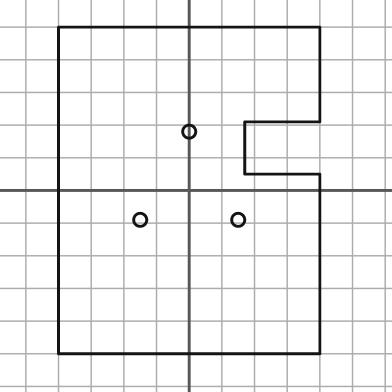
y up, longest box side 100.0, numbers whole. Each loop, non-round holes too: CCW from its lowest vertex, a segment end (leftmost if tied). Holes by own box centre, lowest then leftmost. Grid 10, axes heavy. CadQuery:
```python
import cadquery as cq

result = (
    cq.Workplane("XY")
    .moveTo(-40.0, -50.0)
    .lineTo(40.0, -50.0)
    .lineTo(40.0, 5.0)
    .lineTo(17.0, 5.0)
    .lineTo(17.0, 21.0)
    .lineTo(40.0, 21.0)
    .lineTo(40.0, 50.0)
    .lineTo(-40.0, 50.0)
    .close()
    .moveTo(-15.0, -9.0)
    .circle(2.0)
    .moveTo(15.0, -9.0)
    .circle(2.0)
    .moveTo(0.0, 18.0)
    .circle(2.0)
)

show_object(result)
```